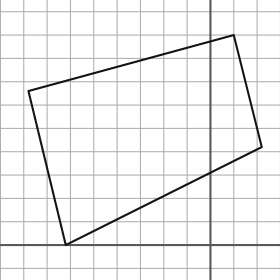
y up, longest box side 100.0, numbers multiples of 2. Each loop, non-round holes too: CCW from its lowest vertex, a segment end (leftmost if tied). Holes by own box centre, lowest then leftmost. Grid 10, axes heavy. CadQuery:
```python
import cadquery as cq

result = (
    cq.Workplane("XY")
    .moveTo(-62.0, 0.0)
    .lineTo(22.0, 42.0)
    .lineTo(10.0, 90.0)
    .lineTo(-78.0, 66.0)
    .close()
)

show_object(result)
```